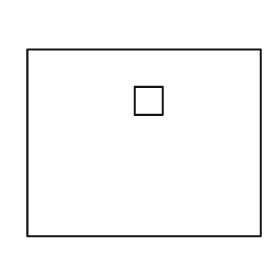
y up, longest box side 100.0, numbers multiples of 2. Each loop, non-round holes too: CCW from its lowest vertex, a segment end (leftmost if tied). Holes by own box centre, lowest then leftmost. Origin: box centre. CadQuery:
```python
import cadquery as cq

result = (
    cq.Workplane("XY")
    .moveTo(-50.0, -40.0)
    .lineTo(50.0, -40.0)
    .lineTo(50.0, 40.0)
    .lineTo(-50.0, 40.0)
    .close()
    .moveTo(-4.0, 12.0)
    .lineTo(8.0, 12.0)
    .lineTo(8.0, 24.0)
    .lineTo(-4.0, 24.0)
    .close()
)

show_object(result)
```